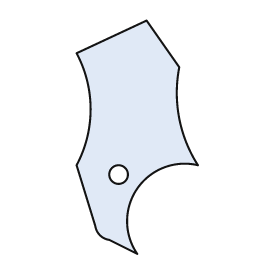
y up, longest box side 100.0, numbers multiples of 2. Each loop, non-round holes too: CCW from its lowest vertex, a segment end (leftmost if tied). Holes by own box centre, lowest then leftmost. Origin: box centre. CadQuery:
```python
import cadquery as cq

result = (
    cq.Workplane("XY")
    .moveTo(0.0, -50.0)
    .threePointArc((0.0, -22.0), (26.0, -12.0))
    .threePointArc((18.0, 8.0), (18.0, 30.0))
    .lineTo(4.0, 50.0)
    .lineTo(-26.0, 36.0)
    .threePointArc((-20.0, 12.0), (-26.0, -12.0))
    .lineTo(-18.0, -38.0)
    .threePointArc((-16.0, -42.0), (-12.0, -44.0))
    .close()
    .moveTo(-8.0, -16.0)
    .circle(4.0)
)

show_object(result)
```